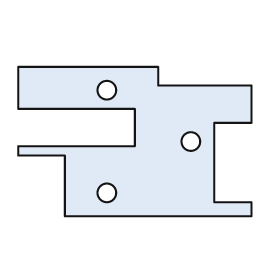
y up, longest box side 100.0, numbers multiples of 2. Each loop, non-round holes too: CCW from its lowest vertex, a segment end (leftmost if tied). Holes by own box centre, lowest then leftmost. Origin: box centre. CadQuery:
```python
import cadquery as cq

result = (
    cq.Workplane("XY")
    .moveTo(-30.0, -32.0)
    .lineTo(50.0, -32.0)
    .lineTo(50.0, -26.0)
    .lineTo(34.0, -26.0)
    .lineTo(34.0, 8.0)
    .lineTo(50.0, 8.0)
    .lineTo(50.0, 24.0)
    .lineTo(10.0, 24.0)
    .lineTo(10.0, 32.0)
    .lineTo(-50.0, 32.0)
    .lineTo(-50.0, 14.0)
    .lineTo(0.0, 14.0)
    .lineTo(0.0, -2.0)
    .lineTo(-50.0, -2.0)
    .lineTo(-50.0, -6.0)
    .lineTo(-30.0, -6.0)
    .close()
    .moveTo(-12.0, -22.0)
    .circle(4.0)
    .moveTo(24.0, 0.0)
    .circle(4.0)
    .moveTo(-12.0, 22.0)
    .circle(4.0)
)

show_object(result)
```